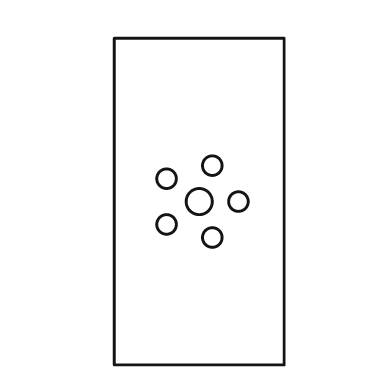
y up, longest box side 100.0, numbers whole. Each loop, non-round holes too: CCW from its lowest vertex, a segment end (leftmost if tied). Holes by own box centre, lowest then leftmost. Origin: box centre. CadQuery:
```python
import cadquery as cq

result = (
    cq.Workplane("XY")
    .moveTo(-26.0, -50.0)
    .lineTo(26.0, -50.0)
    .lineTo(26.0, 50.0)
    .lineTo(-26.0, 50.0)
    .close()
    .moveTo(4.0, -11.0)
    .circle(3.0)
    .moveTo(-10.0, -7.0)
    .circle(3.0)
    .moveTo(0.0, 0.0)
    .circle(4.0)
    .moveTo(12.0, 0.0)
    .circle(3.0)
    .moveTo(-10.0, 7.0)
    .circle(3.0)
    .moveTo(4.0, 11.0)
    .circle(3.0)
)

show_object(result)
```